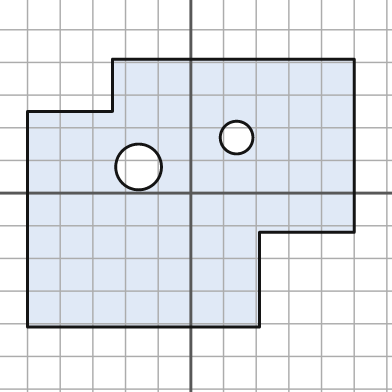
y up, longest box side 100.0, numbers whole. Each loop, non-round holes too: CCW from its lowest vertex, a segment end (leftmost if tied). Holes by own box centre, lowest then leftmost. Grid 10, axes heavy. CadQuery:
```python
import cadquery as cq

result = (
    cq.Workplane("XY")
    .moveTo(-50.0, -41.0)
    .lineTo(21.0, -41.0)
    .lineTo(21.0, -12.0)
    .lineTo(50.0, -12.0)
    .lineTo(50.0, 41.0)
    .lineTo(-24.0, 41.0)
    .lineTo(-24.0, 25.0)
    .lineTo(-50.0, 25.0)
    .close()
    .moveTo(-16.0, 8.0)
    .circle(7.0)
    .moveTo(14.0, 17.0)
    .circle(5.0)
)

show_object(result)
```